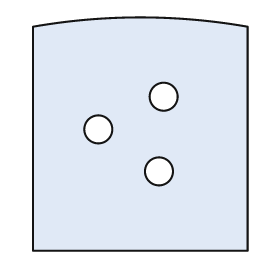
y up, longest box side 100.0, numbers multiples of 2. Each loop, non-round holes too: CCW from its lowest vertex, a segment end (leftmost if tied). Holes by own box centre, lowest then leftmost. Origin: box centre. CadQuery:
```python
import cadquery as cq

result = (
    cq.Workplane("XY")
    .moveTo(-46.0, -50.0)
    .lineTo(46.0, -50.0)
    .lineTo(46.0, 46.0)
    .threePointArc((0.0, 50.0), (-46.0, 46.0))
    .close()
    .moveTo(8.0, -16.0)
    .circle(6.0)
    .moveTo(-18.0, 2.0)
    .circle(6.0)
    .moveTo(10.0, 16.0)
    .circle(6.0)
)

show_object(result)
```